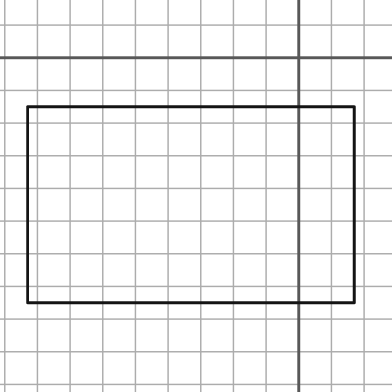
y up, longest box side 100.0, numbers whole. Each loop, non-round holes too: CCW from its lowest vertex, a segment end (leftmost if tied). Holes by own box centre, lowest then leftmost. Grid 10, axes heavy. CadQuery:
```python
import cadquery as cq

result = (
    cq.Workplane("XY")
    .moveTo(-83.0, -75.0)
    .lineTo(17.0, -75.0)
    .lineTo(17.0, -15.0)
    .lineTo(-83.0, -15.0)
    .close()
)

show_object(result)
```